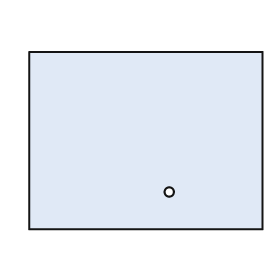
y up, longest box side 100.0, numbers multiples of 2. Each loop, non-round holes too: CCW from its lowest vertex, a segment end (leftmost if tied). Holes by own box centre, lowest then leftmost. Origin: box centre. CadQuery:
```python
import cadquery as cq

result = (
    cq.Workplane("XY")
    .moveTo(-50.0, -38.0)
    .lineTo(50.0, -38.0)
    .lineTo(50.0, 38.0)
    .lineTo(-50.0, 38.0)
    .close()
    .moveTo(10.0, -22.0)
    .circle(2.0)
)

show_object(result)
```